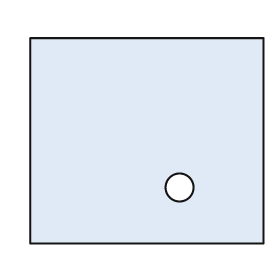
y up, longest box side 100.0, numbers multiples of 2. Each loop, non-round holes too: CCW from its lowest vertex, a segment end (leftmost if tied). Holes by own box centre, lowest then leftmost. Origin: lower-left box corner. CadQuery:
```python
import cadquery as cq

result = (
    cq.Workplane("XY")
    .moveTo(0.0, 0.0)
    .lineTo(100.0, 0.0)
    .lineTo(100.0, 88.0)
    .lineTo(0.0, 88.0)
    .close()
    .moveTo(64.0, 24.0)
    .circle(6.0)
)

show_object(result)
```